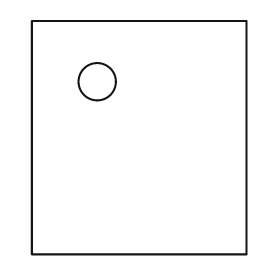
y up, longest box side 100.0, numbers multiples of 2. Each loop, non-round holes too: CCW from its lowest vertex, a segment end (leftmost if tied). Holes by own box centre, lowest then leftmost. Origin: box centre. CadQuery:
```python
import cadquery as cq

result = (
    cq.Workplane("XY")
    .moveTo(-46.0, -50.0)
    .lineTo(46.0, -50.0)
    .lineTo(46.0, 50.0)
    .lineTo(-46.0, 50.0)
    .close()
    .moveTo(-18.0, 24.0)
    .circle(8.0)
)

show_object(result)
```